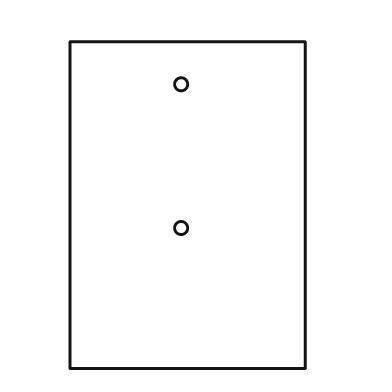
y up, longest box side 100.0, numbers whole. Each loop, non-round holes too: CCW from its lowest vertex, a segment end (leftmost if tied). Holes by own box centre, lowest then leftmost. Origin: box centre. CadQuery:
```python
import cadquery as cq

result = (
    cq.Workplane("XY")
    .moveTo(-36.0, -50.0)
    .lineTo(36.0, -50.0)
    .lineTo(36.0, 50.0)
    .lineTo(-36.0, 50.0)
    .close()
    .moveTo(-2.0, -7.0)
    .circle(2.0)
    .moveTo(-2.0, 37.0)
    .circle(2.0)
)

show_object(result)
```